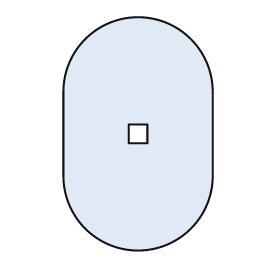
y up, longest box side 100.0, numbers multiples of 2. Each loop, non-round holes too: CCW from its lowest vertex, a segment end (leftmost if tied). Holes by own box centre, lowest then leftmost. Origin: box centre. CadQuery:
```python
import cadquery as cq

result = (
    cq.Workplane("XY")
    .moveTo(-32.0, -18.0)
    .threePointArc((0.0, -50.0), (32.0, -18.0))
    .lineTo(32.0, 18.0)
    .threePointArc((0.0, 50.0), (-32.0, 18.0))
    .close()
    .moveTo(-4.0, -4.0)
    .lineTo(4.0, -4.0)
    .lineTo(4.0, 4.0)
    .lineTo(-4.0, 4.0)
    .close()
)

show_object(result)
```